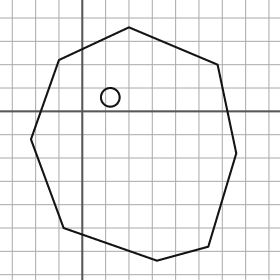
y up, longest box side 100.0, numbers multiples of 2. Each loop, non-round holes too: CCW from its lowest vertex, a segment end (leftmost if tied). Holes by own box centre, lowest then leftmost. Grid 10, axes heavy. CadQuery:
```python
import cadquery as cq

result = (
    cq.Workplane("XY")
    .moveTo(32.0, -64.0)
    .lineTo(54.0, -58.0)
    .lineTo(66.0, -18.0)
    .lineTo(58.0, 20.0)
    .lineTo(20.0, 36.0)
    .lineTo(-10.0, 22.0)
    .lineTo(-22.0, -12.0)
    .lineTo(-8.0, -50.0)
    .close()
    .moveTo(12.0, 6.0)
    .circle(4.0)
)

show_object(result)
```